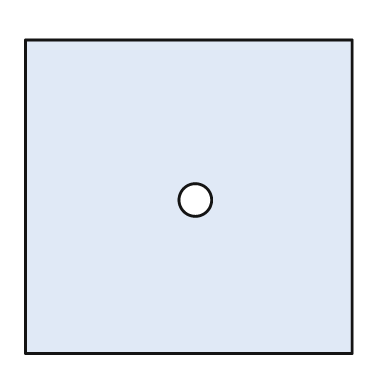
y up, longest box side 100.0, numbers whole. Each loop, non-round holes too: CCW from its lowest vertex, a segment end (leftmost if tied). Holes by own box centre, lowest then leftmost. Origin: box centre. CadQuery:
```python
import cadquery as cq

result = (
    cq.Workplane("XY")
    .moveTo(-50.0, -48.0)
    .lineTo(50.0, -48.0)
    .lineTo(50.0, 48.0)
    .lineTo(-50.0, 48.0)
    .close()
    .moveTo(2.0, -1.0)
    .circle(5.0)
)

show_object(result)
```